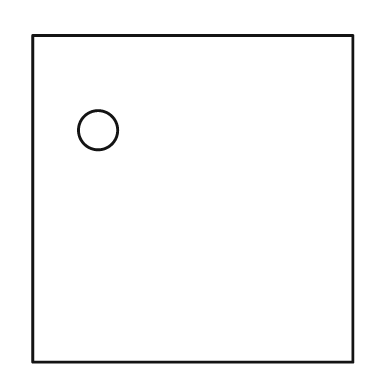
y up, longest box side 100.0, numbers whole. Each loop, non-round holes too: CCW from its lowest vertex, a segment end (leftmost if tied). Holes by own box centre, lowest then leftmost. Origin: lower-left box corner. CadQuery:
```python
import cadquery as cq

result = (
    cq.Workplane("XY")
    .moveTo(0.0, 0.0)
    .lineTo(98.0, 0.0)
    .lineTo(98.0, 100.0)
    .lineTo(0.0, 100.0)
    .close()
    .moveTo(20.0, 71.0)
    .circle(6.0)
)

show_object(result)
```